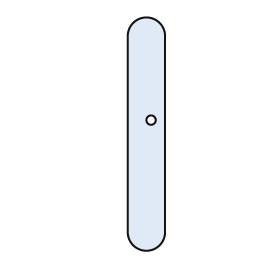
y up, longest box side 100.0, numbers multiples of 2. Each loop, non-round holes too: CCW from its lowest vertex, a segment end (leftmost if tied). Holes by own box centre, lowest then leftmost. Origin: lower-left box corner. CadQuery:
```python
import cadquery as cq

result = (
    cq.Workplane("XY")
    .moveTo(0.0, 8.0)
    .threePointArc((8.0, 0.0), (16.0, 8.0))
    .lineTo(16.0, 92.0)
    .threePointArc((8.0, 100.0), (0.0, 92.0))
    .close()
    .moveTo(10.0, 56.0)
    .circle(2.0)
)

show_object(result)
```